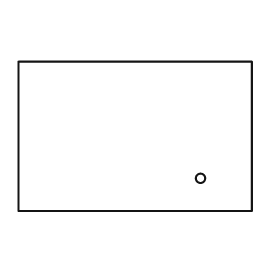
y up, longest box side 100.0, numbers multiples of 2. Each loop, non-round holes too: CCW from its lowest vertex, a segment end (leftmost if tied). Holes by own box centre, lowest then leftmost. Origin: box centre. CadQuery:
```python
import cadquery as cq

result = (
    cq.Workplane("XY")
    .moveTo(-50.0, -32.0)
    .lineTo(50.0, -32.0)
    .lineTo(50.0, 32.0)
    .lineTo(-50.0, 32.0)
    .close()
    .moveTo(28.0, -18.0)
    .circle(2.0)
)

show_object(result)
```